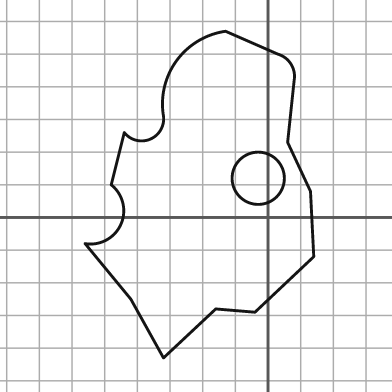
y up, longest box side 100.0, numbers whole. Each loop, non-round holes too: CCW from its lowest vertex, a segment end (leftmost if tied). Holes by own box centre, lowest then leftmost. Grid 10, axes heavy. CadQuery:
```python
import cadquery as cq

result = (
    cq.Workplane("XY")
    .moveTo(-32.0, -43.0)
    .lineTo(-16.0, -28.0)
    .lineTo(-4.0, -29.0)
    .lineTo(14.0, -12.0)
    .lineTo(13.0, 8.0)
    .lineTo(6.0, 23.0)
    .lineTo(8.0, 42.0)
    .threePointArc((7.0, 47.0), (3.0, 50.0))
    .lineTo(-13.0, 57.0)
    .threePointArc((-28.0, 48.0), (-32.0, 31.0))
    .threePointArc((-36.0, 24.0), (-44.0, 26.0))
    .lineTo(-48.0, 10.0)
    .threePointArc((-45.0, -2.0), (-56.0, -8.0))
    .lineTo(-42.0, -25.0)
    .close()
    .moveTo(-3.0, 12.0)
    .circle(8.0)
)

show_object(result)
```